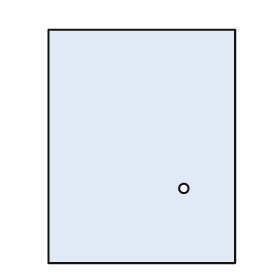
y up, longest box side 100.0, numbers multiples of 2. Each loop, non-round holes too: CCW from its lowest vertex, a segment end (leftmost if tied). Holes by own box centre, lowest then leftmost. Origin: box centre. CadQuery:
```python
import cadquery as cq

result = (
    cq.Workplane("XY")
    .moveTo(-40.0, -50.0)
    .lineTo(40.0, -50.0)
    .lineTo(40.0, 50.0)
    .lineTo(-40.0, 50.0)
    .close()
    .moveTo(18.0, -18.0)
    .circle(2.0)
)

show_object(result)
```